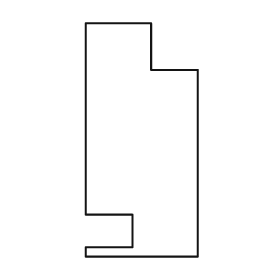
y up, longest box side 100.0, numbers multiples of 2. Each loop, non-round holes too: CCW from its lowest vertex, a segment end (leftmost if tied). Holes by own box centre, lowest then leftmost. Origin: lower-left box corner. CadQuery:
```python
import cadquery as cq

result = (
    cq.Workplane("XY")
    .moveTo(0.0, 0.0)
    .lineTo(48.0, 0.0)
    .lineTo(48.0, 80.0)
    .lineTo(28.0, 80.0)
    .lineTo(28.0, 100.0)
    .lineTo(0.0, 100.0)
    .lineTo(0.0, 18.0)
    .lineTo(20.0, 18.0)
    .lineTo(20.0, 4.0)
    .lineTo(0.0, 4.0)
    .close()
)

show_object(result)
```